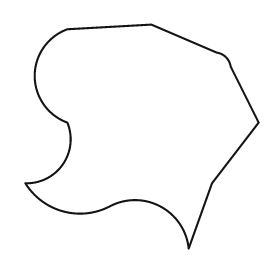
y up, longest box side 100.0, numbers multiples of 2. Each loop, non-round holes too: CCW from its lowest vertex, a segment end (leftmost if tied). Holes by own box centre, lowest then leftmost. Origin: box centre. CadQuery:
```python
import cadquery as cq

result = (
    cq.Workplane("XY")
    .moveTo(20.0, -48.0)
    .lineTo(30.0, -20.0)
    .lineTo(50.0, 6.0)
    .lineTo(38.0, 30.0)
    .threePointArc((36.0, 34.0), (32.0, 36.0))
    .lineTo(4.0, 48.0)
    .lineTo(-32.0, 46.0)
    .threePointArc((-46.0, 26.0), (-32.0, 6.0))
    .threePointArc((-34.0, -12.0), (-50.0, -20.0))
    .threePointArc((-34.0, -32.0), (-14.0, -30.0))
    .threePointArc((8.0, -30.0), (20.0, -48.0))
    .close()
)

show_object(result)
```